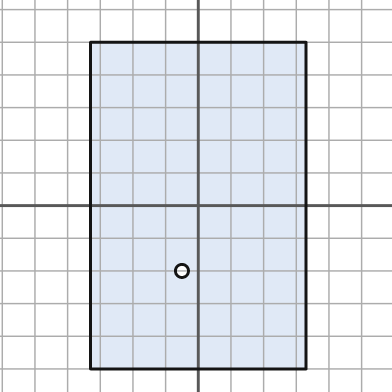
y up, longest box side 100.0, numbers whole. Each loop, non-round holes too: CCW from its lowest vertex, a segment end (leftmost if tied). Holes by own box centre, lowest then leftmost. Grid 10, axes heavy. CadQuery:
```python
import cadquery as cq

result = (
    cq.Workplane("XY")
    .moveTo(-33.0, -50.0)
    .lineTo(33.0, -50.0)
    .lineTo(33.0, 50.0)
    .lineTo(-33.0, 50.0)
    .close()
    .moveTo(-5.0, -20.0)
    .circle(2.0)
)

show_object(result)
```